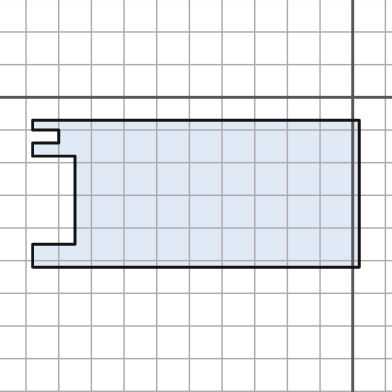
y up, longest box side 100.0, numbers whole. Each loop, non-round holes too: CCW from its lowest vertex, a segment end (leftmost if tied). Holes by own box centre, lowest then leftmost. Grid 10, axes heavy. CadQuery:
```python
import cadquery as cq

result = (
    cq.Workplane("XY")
    .moveTo(-98.0, -52.0)
    .lineTo(2.0, -52.0)
    .lineTo(2.0, -7.0)
    .lineTo(-98.0, -7.0)
    .lineTo(-98.0, -10.0)
    .lineTo(-90.0, -10.0)
    .lineTo(-90.0, -14.0)
    .lineTo(-98.0, -14.0)
    .lineTo(-98.0, -18.0)
    .lineTo(-85.0, -18.0)
    .lineTo(-85.0, -45.0)
    .lineTo(-98.0, -45.0)
    .close()
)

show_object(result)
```